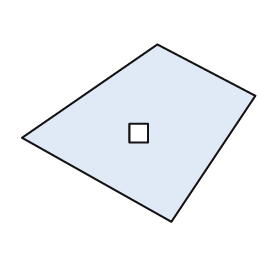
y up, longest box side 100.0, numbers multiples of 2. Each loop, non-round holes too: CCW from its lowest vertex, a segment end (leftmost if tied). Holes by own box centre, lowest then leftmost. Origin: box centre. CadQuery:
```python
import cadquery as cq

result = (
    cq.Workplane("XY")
    .moveTo(14.0, -38.0)
    .lineTo(50.0, 16.0)
    .lineTo(8.0, 38.0)
    .lineTo(-50.0, -2.0)
    .close()
    .moveTo(-4.0, -4.0)
    .lineTo(4.0, -4.0)
    .lineTo(4.0, 4.0)
    .lineTo(-4.0, 4.0)
    .close()
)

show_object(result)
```